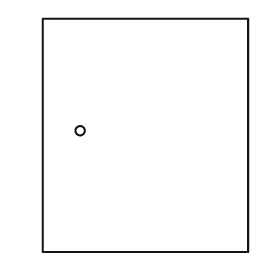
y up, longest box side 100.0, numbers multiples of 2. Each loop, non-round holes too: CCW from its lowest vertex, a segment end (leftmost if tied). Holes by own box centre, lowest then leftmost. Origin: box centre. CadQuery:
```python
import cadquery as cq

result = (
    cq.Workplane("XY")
    .moveTo(-44.0, -50.0)
    .lineTo(44.0, -50.0)
    .lineTo(44.0, 50.0)
    .lineTo(-44.0, 50.0)
    .close()
    .moveTo(-28.0, 2.0)
    .circle(2.0)
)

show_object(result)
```